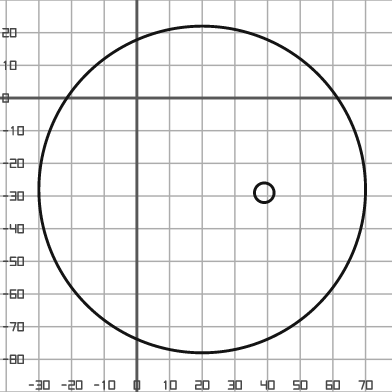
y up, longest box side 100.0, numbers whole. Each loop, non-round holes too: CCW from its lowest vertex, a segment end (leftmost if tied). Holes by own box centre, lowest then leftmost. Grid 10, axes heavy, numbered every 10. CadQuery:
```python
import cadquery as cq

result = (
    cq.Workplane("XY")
    .moveTo(20.0, -28.0)
    .circle(50.0)
    .moveTo(39.0, -29.0)
    .circle(3.0)
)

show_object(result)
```